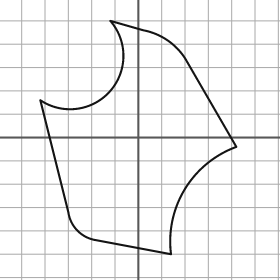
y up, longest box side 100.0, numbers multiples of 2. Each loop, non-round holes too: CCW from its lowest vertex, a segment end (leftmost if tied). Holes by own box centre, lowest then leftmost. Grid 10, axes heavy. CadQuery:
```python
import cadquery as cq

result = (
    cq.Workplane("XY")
    .moveTo(14.0, -50.0)
    .threePointArc((20.0, -22.0), (42.0, -4.0))
    .lineTo(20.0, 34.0)
    .threePointArc((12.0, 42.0), (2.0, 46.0))
    .lineTo(-12.0, 50.0)
    .threePointArc((-12.0, 20.0), (-42.0, 16.0))
    .lineTo(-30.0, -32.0)
    .threePointArc((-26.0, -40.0), (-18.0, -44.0))
    .close()
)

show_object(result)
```